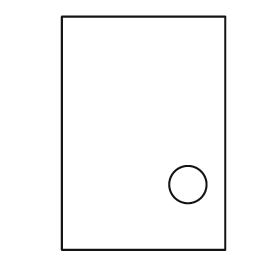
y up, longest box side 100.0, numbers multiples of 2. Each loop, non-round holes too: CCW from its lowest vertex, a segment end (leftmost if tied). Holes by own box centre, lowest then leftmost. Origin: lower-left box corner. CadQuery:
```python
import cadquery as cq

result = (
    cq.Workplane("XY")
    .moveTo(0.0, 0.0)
    .lineTo(70.0, 0.0)
    .lineTo(70.0, 100.0)
    .lineTo(0.0, 100.0)
    .close()
    .moveTo(54.0, 28.0)
    .circle(8.0)
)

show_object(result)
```